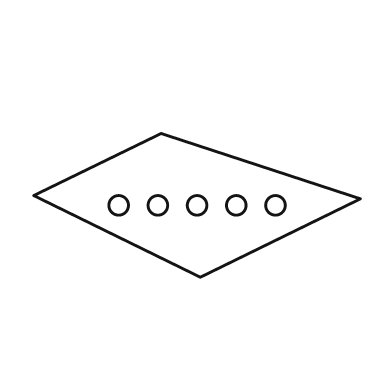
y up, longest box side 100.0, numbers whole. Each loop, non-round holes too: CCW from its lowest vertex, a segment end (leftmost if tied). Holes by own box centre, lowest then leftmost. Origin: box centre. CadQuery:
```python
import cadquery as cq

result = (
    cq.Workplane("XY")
    .moveTo(1.0, -22.0)
    .lineTo(50.0, 2.0)
    .lineTo(-11.0, 22.0)
    .lineTo(-50.0, 3.0)
    .close()
    .moveTo(-24.0, 0.0)
    .circle(3.0)
    .moveTo(-12.0, 0.0)
    .circle(3.0)
    .moveTo(0.0, 0.0)
    .circle(3.0)
    .moveTo(12.0, 0.0)
    .circle(3.0)
    .moveTo(24.0, 0.0)
    .circle(3.0)
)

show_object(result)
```